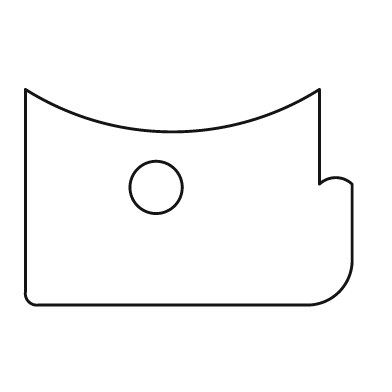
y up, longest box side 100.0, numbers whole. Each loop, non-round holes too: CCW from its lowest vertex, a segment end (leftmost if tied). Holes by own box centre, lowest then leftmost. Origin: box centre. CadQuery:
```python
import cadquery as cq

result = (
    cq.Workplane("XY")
    .moveTo(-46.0, -33.0)
    .lineTo(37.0, -33.0)
    .threePointArc((46.0, -29.0), (50.0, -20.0))
    .lineTo(50.0, 4.0)
    .threePointArc((45.0, 6.0), (40.0, 4.0))
    .lineTo(40.0, 33.0)
    .threePointArc((-5.0, 20.0), (-50.0, 33.0))
    .lineTo(-50.0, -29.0)
    .threePointArc((-49.0, -32.0), (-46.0, -33.0))
    .close()
    .moveTo(-10.0, 3.0)
    .circle(8.0)
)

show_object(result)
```